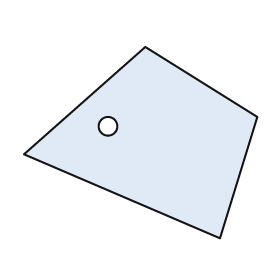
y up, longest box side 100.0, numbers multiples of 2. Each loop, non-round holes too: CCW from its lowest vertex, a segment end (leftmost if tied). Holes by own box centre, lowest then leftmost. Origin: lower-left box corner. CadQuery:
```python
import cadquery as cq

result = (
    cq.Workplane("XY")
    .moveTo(84.0, 0.0)
    .lineTo(100.0, 52.0)
    .lineTo(52.0, 82.0)
    .lineTo(0.0, 36.0)
    .close()
    .moveTo(36.0, 48.0)
    .circle(4.0)
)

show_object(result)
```